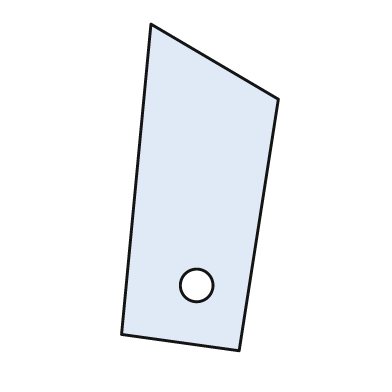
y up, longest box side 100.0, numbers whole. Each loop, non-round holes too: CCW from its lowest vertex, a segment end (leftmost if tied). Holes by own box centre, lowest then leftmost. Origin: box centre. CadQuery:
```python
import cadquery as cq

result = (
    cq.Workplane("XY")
    .moveTo(12.0, -50.0)
    .lineTo(24.0, 27.0)
    .lineTo(-15.0, 50.0)
    .lineTo(-24.0, -45.0)
    .close()
    .moveTo(-1.0, -30.0)
    .circle(5.0)
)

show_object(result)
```